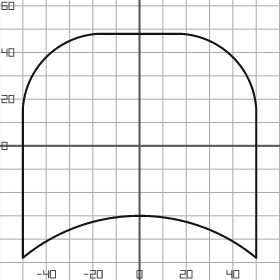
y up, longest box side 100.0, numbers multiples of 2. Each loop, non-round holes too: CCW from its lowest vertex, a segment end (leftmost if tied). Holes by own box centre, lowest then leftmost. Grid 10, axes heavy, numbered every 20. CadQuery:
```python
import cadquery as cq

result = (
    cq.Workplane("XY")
    .moveTo(-50.0, -48.0)
    .threePointArc((0.0, -30.0), (50.0, -48.0))
    .lineTo(50.0, 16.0)
    .threePointArc((40.0, 38.0), (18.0, 48.0))
    .lineTo(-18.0, 48.0)
    .threePointArc((-40.0, 38.0), (-50.0, 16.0))
    .close()
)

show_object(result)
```